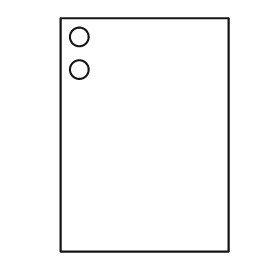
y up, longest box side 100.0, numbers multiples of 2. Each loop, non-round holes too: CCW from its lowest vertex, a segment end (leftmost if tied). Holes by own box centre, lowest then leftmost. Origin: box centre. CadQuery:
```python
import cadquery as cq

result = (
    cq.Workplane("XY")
    .moveTo(-36.0, -50.0)
    .lineTo(36.0, -50.0)
    .lineTo(36.0, 50.0)
    .lineTo(-36.0, 50.0)
    .close()
    .moveTo(-28.0, 28.0)
    .circle(4.0)
    .moveTo(-28.0, 42.0)
    .circle(4.0)
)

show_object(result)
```